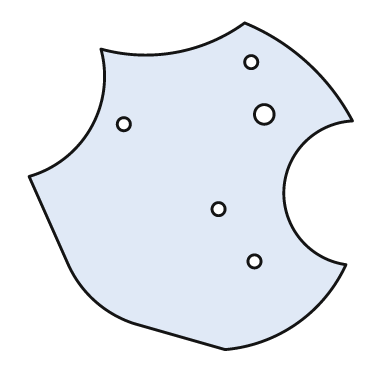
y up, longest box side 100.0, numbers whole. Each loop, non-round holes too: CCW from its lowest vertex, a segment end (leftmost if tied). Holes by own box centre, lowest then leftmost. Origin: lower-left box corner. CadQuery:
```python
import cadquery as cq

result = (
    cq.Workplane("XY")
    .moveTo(60.0, 0.0)
    .threePointArc((82.0, 8.0), (97.0, 26.0))
    .threePointArc((78.0, 49.0), (99.0, 70.0))
    .threePointArc((85.0, 88.0), (66.0, 100.0))
    .threePointArc((45.0, 91.0), (22.0, 92.0))
    .threePointArc((19.0, 68.0), (0.0, 53.0))
    .lineTo(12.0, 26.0)
    .threePointArc((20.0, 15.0), (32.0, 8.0))
    .close()
    .moveTo(69.0, 27.0)
    .circle(2.0)
    .moveTo(58.0, 43.0)
    .circle(2.0)
    .moveTo(29.0, 69.0)
    .circle(2.0)
    .moveTo(72.0, 72.0)
    .circle(3.0)
    .moveTo(68.0, 88.0)
    .circle(2.0)
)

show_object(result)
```